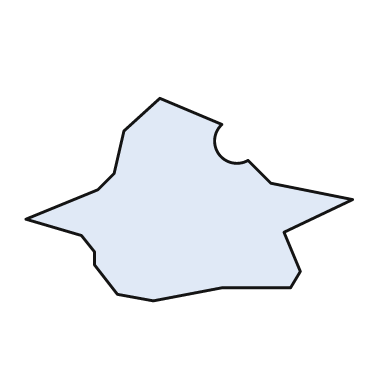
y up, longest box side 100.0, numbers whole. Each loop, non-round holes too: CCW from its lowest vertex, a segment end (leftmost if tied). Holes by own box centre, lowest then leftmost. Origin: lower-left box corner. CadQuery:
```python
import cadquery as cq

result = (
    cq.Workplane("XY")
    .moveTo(39.0, 0.0)
    .lineTo(60.0, 4.0)
    .lineTo(81.0, 4.0)
    .lineTo(84.0, 9.0)
    .lineTo(79.0, 21.0)
    .lineTo(100.0, 31.0)
    .lineTo(75.0, 36.0)
    .lineTo(68.0, 43.0)
    .threePointArc((59.0, 45.0), (60.0, 54.0))
    .lineTo(41.0, 62.0)
    .lineTo(30.0, 52.0)
    .lineTo(27.0, 39.0)
    .lineTo(22.0, 34.0)
    .lineTo(0.0, 25.0)
    .lineTo(17.0, 20.0)
    .lineTo(21.0, 15.0)
    .lineTo(21.0, 11.0)
    .lineTo(28.0, 2.0)
    .close()
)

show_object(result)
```